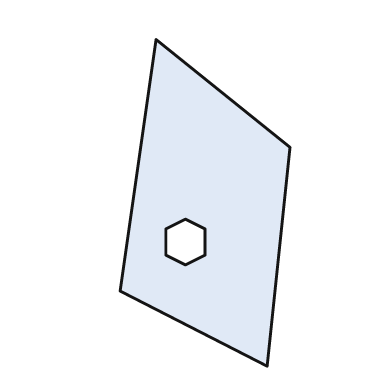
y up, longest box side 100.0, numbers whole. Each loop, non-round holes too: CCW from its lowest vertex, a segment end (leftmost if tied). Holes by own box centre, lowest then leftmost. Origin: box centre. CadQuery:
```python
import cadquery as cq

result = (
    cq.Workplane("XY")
    .moveTo(19.0, -50.0)
    .lineTo(26.0, 17.0)
    .lineTo(-15.0, 50.0)
    .lineTo(-26.0, -27.0)
    .close()
    .moveTo(-6.0, -19.0)
    .lineTo(0.0, -16.0)
    .lineTo(0.0, -8.0)
    .lineTo(-6.0, -5.0)
    .lineTo(-12.0, -8.0)
    .lineTo(-12.0, -16.0)
    .close()
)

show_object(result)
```